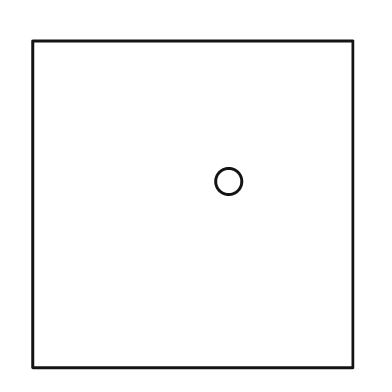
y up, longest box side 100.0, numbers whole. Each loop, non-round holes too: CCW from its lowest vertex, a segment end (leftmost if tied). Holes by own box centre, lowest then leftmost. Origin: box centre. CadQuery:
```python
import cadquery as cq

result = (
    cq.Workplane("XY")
    .moveTo(-49.0, -50.0)
    .lineTo(49.0, -50.0)
    .lineTo(49.0, 50.0)
    .lineTo(-49.0, 50.0)
    .close()
    .moveTo(11.0, 7.0)
    .circle(4.0)
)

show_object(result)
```